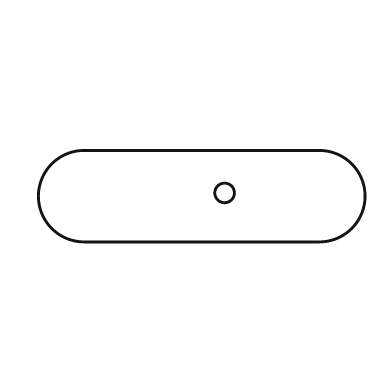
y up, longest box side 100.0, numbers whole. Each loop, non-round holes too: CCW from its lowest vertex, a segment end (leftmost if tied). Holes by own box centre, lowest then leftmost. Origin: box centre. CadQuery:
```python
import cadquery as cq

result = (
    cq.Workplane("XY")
    .moveTo(-36.0, -14.0)
    .lineTo(36.0, -14.0)
    .threePointArc((50.0, 0.0), (36.0, 14.0))
    .lineTo(-36.0, 14.0)
    .threePointArc((-50.0, 0.0), (-36.0, -14.0))
    .close()
    .moveTo(7.0, 1.0)
    .circle(3.0)
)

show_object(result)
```